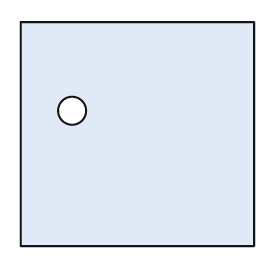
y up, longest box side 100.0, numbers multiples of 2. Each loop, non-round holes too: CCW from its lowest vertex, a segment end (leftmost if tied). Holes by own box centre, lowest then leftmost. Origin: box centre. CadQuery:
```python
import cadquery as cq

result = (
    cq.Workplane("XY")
    .moveTo(-50.0, -48.0)
    .lineTo(50.0, -48.0)
    .lineTo(50.0, 48.0)
    .lineTo(-50.0, 48.0)
    .close()
    .moveTo(-28.0, 10.0)
    .circle(6.0)
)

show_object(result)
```